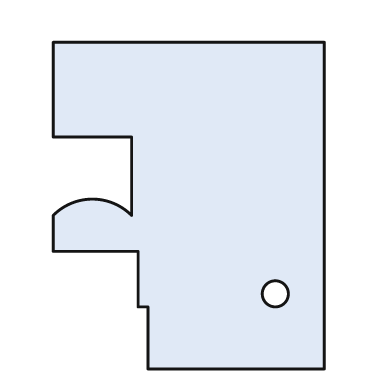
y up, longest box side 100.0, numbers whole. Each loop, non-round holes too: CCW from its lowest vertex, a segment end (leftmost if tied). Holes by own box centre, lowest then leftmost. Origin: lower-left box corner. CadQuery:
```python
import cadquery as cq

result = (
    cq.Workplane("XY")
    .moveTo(29.0, 0.0)
    .lineTo(83.0, 0.0)
    .lineTo(83.0, 100.0)
    .lineTo(0.0, 100.0)
    .lineTo(0.0, 71.0)
    .lineTo(24.0, 71.0)
    .lineTo(24.0, 47.0)
    .threePointArc((12.0, 52.0), (0.0, 47.0))
    .lineTo(0.0, 36.0)
    .lineTo(26.0, 36.0)
    .lineTo(26.0, 19.0)
    .lineTo(29.0, 19.0)
    .close()
    .moveTo(68.0, 23.0)
    .circle(4.0)
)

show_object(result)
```